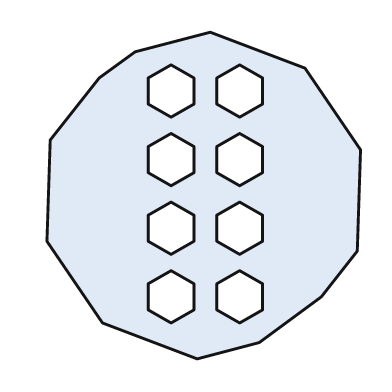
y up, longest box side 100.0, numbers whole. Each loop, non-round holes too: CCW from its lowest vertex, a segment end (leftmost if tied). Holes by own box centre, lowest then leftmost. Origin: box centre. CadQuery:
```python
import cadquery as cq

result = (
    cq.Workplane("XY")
    .moveTo(-2.0, -50.0)
    .lineTo(17.0, -45.0)
    .lineTo(36.0, -31.0)
    .lineTo(47.0, -17.0)
    .lineTo(48.0, 14.0)
    .lineTo(31.0, 39.0)
    .lineTo(2.0, 50.0)
    .lineTo(-21.0, 44.0)
    .lineTo(-32.0, 36.0)
    .lineTo(-47.0, 17.0)
    .lineTo(-48.0, -14.0)
    .lineTo(-31.0, -39.0)
    .close()
    .moveTo(-10.0, -39.0)
    .lineTo(-3.0, -35.0)
    .lineTo(-3.0, -27.0)
    .lineTo(-10.0, -23.0)
    .lineTo(-17.0, -27.0)
    .lineTo(-17.0, -35.0)
    .close()
    .moveTo(11.0, -39.0)
    .lineTo(18.0, -35.0)
    .lineTo(18.0, -27.0)
    .lineTo(11.0, -23.0)
    .lineTo(4.0, -27.0)
    .lineTo(4.0, -35.0)
    .close()
    .moveTo(-10.0, -18.0)
    .lineTo(-3.0, -14.0)
    .lineTo(-3.0, -6.0)
    .lineTo(-10.0, -2.0)
    .lineTo(-17.0, -6.0)
    .lineTo(-17.0, -14.0)
    .close()
    .moveTo(11.0, -18.0)
    .lineTo(18.0, -14.0)
    .lineTo(18.0, -6.0)
    .lineTo(11.0, -2.0)
    .lineTo(4.0, -6.0)
    .lineTo(4.0, -14.0)
    .close()
    .moveTo(-10.0, 3.0)
    .lineTo(-3.0, 7.0)
    .lineTo(-3.0, 15.0)
    .lineTo(-10.0, 19.0)
    .lineTo(-17.0, 15.0)
    .lineTo(-17.0, 7.0)
    .close()
    .moveTo(11.0, 3.0)
    .lineTo(18.0, 7.0)
    .lineTo(18.0, 15.0)
    .lineTo(11.0, 19.0)
    .lineTo(4.0, 15.0)
    .lineTo(4.0, 7.0)
    .close()
    .moveTo(-10.0, 24.0)
    .lineTo(-3.0, 28.0)
    .lineTo(-3.0, 36.0)
    .lineTo(-10.0, 40.0)
    .lineTo(-17.0, 36.0)
    .lineTo(-17.0, 28.0)
    .close()
    .moveTo(11.0, 24.0)
    .lineTo(18.0, 28.0)
    .lineTo(18.0, 36.0)
    .lineTo(11.0, 40.0)
    .lineTo(4.0, 36.0)
    .lineTo(4.0, 28.0)
    .close()
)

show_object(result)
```